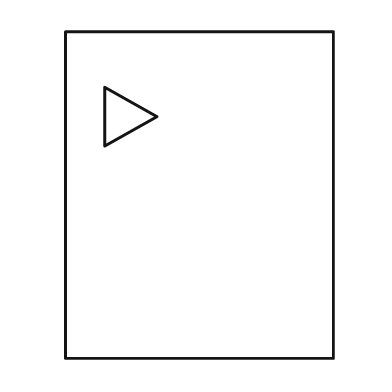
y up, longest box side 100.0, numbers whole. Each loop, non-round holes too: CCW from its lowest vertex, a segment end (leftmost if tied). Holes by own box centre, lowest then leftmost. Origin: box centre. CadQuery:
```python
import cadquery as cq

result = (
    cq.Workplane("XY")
    .moveTo(-41.0, -50.0)
    .lineTo(41.0, -50.0)
    .lineTo(41.0, 50.0)
    .lineTo(-41.0, 50.0)
    .close()
    .moveTo(-29.0, 15.0)
    .lineTo(-13.0, 24.0)
    .lineTo(-29.0, 33.0)
    .close()
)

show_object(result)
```